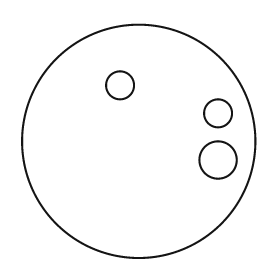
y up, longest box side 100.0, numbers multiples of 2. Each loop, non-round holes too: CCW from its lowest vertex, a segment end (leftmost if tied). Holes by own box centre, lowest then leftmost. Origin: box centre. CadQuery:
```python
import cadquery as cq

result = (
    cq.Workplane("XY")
    .moveTo(0.0, 0.0)
    .circle(50.0)
    .moveTo(34.0, -8.0)
    .circle(8.0)
    .moveTo(34.0, 12.0)
    .circle(6.0)
    .moveTo(-8.0, 24.0)
    .circle(6.0)
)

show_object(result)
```